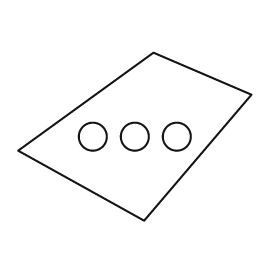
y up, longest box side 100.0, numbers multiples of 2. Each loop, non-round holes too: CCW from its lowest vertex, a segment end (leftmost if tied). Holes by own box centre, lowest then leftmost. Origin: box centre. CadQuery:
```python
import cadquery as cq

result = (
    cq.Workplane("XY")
    .moveTo(4.0, -36.0)
    .lineTo(50.0, 18.0)
    .lineTo(8.0, 36.0)
    .lineTo(-50.0, -6.0)
    .close()
    .moveTo(-18.0, 0.0)
    .circle(6.0)
    .moveTo(0.0, 0.0)
    .circle(6.0)
    .moveTo(18.0, 0.0)
    .circle(6.0)
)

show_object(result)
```